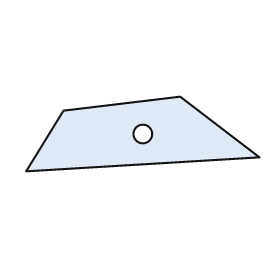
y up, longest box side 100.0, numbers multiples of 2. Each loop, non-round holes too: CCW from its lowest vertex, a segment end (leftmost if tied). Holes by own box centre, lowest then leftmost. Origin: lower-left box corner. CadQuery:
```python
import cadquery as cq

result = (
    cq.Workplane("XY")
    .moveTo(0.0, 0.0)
    .lineTo(100.0, 6.0)
    .lineTo(66.0, 32.0)
    .lineTo(16.0, 26.0)
    .close()
    .moveTo(50.0, 16.0)
    .circle(4.0)
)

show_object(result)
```